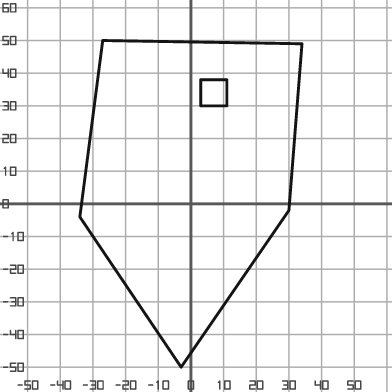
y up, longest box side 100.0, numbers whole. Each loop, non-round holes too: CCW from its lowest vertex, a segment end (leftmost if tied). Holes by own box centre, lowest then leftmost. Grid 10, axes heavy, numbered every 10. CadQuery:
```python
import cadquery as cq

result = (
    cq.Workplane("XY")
    .moveTo(-3.0, -50.0)
    .lineTo(30.0, -2.0)
    .lineTo(34.0, 49.0)
    .lineTo(-27.0, 50.0)
    .lineTo(-34.0, -4.0)
    .close()
    .moveTo(3.0, 30.0)
    .lineTo(11.0, 30.0)
    .lineTo(11.0, 38.0)
    .lineTo(3.0, 38.0)
    .close()
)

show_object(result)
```